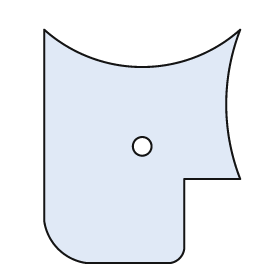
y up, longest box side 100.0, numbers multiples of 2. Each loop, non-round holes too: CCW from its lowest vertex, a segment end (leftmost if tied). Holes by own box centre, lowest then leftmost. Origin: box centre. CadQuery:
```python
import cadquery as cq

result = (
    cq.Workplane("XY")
    .moveTo(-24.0, -50.0)
    .lineTo(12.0, -50.0)
    .threePointArc((16.0, -48.0), (18.0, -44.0))
    .lineTo(18.0, -14.0)
    .lineTo(42.0, -14.0)
    .threePointArc((36.0, 18.0), (42.0, 50.0))
    .threePointArc((0.0, 34.0), (-42.0, 50.0))
    .lineTo(-42.0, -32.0)
    .threePointArc((-36.0, -44.0), (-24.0, -50.0))
    .close()
    .moveTo(0.0, 0.0)
    .circle(4.0)
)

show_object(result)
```